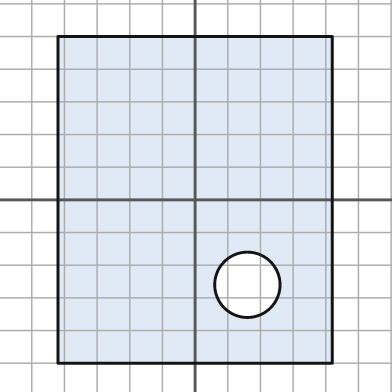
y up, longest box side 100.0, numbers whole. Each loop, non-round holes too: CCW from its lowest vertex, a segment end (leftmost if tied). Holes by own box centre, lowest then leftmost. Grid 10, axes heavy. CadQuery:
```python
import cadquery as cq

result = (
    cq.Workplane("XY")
    .moveTo(-42.0, -50.0)
    .lineTo(42.0, -50.0)
    .lineTo(42.0, 50.0)
    .lineTo(-42.0, 50.0)
    .close()
    .moveTo(16.0, -26.0)
    .circle(10.0)
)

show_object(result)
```